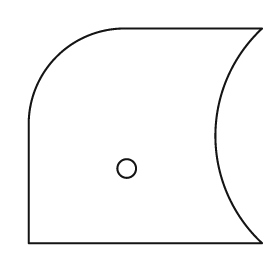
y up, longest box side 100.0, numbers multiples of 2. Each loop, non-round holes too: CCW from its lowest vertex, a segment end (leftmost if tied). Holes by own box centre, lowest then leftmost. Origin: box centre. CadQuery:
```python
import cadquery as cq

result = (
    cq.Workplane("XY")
    .moveTo(-50.0, -46.0)
    .lineTo(50.0, -46.0)
    .threePointArc((30.0, 0.0), (50.0, 46.0))
    .lineTo(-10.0, 46.0)
    .threePointArc((-38.0, 34.0), (-50.0, 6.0))
    .close()
    .moveTo(-8.0, -14.0)
    .circle(4.0)
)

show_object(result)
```